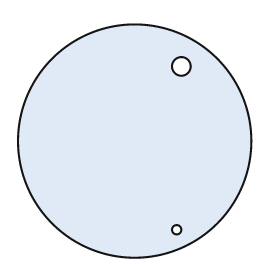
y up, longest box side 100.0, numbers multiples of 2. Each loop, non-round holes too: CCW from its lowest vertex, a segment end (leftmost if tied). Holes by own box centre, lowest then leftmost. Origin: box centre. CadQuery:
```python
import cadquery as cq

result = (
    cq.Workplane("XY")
    .moveTo(0.0, 0.0)
    .circle(50.0)
    .moveTo(18.0, -38.0)
    .circle(2.0)
    .moveTo(20.0, 32.0)
    .circle(4.0)
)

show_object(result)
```